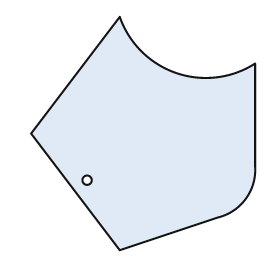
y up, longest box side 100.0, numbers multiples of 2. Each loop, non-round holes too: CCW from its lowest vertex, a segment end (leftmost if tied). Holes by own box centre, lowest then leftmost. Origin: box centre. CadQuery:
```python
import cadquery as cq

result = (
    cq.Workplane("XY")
    .moveTo(-10.0, -50.0)
    .lineTo(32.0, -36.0)
    .threePointArc((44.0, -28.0), (48.0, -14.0))
    .lineTo(48.0, 30.0)
    .threePointArc((14.0, 26.0), (-10.0, 50.0))
    .lineTo(-48.0, 0.0)
    .close()
    .moveTo(-24.0, -20.0)
    .circle(2.0)
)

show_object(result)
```